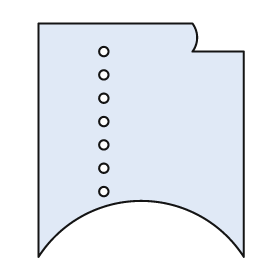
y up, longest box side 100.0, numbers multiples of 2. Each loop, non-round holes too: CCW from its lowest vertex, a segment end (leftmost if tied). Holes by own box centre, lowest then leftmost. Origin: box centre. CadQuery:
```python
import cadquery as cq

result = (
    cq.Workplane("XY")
    .moveTo(-44.0, -50.0)
    .threePointArc((0.0, -26.0), (44.0, -50.0))
    .lineTo(44.0, 38.0)
    .lineTo(22.0, 38.0)
    .threePointArc((24.0, 44.0), (22.0, 50.0))
    .lineTo(-44.0, 50.0)
    .close()
    .moveTo(-16.0, -22.0)
    .circle(2.0)
    .moveTo(-16.0, -12.0)
    .circle(2.0)
    .moveTo(-16.0, -2.0)
    .circle(2.0)
    .moveTo(-16.0, 8.0)
    .circle(2.0)
    .moveTo(-16.0, 18.0)
    .circle(2.0)
    .moveTo(-16.0, 28.0)
    .circle(2.0)
    .moveTo(-16.0, 38.0)
    .circle(2.0)
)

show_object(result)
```